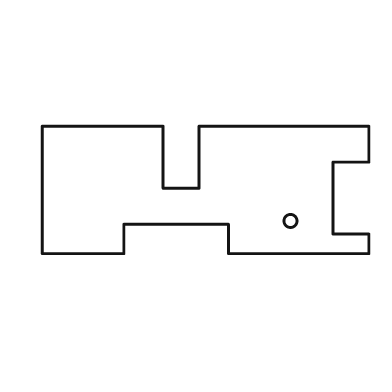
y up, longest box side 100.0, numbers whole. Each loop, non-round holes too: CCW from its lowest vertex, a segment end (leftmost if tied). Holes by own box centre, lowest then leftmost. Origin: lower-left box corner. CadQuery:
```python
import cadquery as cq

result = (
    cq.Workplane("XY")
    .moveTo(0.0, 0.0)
    .lineTo(25.0, 0.0)
    .lineTo(25.0, 9.0)
    .lineTo(57.0, 9.0)
    .lineTo(57.0, 0.0)
    .lineTo(100.0, 0.0)
    .lineTo(100.0, 6.0)
    .lineTo(89.0, 6.0)
    .lineTo(89.0, 28.0)
    .lineTo(100.0, 28.0)
    .lineTo(100.0, 39.0)
    .lineTo(48.0, 39.0)
    .lineTo(48.0, 20.0)
    .lineTo(37.0, 20.0)
    .lineTo(37.0, 39.0)
    .lineTo(0.0, 39.0)
    .close()
    .moveTo(76.0, 10.0)
    .circle(2.0)
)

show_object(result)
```